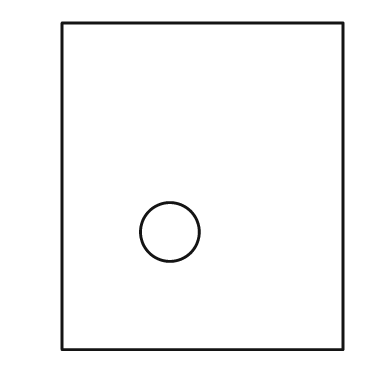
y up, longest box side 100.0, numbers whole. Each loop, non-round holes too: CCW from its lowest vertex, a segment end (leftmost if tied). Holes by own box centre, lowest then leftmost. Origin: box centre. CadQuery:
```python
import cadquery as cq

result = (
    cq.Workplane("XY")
    .moveTo(-43.0, -50.0)
    .lineTo(43.0, -50.0)
    .lineTo(43.0, 50.0)
    .lineTo(-43.0, 50.0)
    .close()
    .moveTo(-10.0, -14.0)
    .circle(9.0)
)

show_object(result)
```